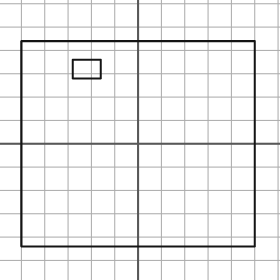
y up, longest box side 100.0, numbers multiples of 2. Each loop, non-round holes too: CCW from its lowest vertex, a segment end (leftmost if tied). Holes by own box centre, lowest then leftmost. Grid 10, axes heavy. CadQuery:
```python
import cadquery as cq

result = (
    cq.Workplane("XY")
    .moveTo(-50.0, -44.0)
    .lineTo(50.0, -44.0)
    .lineTo(50.0, 44.0)
    .lineTo(-50.0, 44.0)
    .close()
    .moveTo(-28.0, 28.0)
    .lineTo(-16.0, 28.0)
    .lineTo(-16.0, 36.0)
    .lineTo(-28.0, 36.0)
    .close()
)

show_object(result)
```